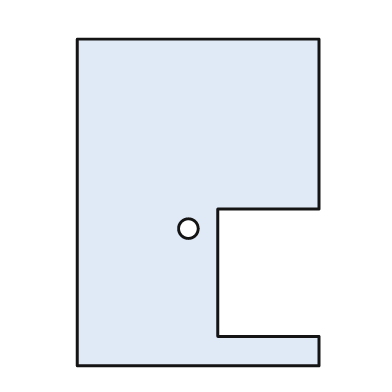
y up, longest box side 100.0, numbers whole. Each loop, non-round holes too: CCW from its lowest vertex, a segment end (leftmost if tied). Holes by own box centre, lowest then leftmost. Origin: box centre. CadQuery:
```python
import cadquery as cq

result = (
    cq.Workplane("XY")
    .moveTo(-37.0, -50.0)
    .lineTo(37.0, -50.0)
    .lineTo(37.0, -41.0)
    .lineTo(6.0, -41.0)
    .lineTo(6.0, -2.0)
    .lineTo(37.0, -2.0)
    .lineTo(37.0, 50.0)
    .lineTo(-37.0, 50.0)
    .close()
    .moveTo(-3.0, -8.0)
    .circle(3.0)
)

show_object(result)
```